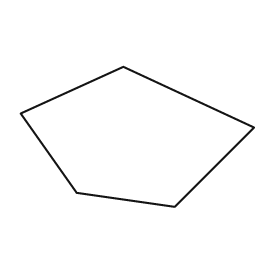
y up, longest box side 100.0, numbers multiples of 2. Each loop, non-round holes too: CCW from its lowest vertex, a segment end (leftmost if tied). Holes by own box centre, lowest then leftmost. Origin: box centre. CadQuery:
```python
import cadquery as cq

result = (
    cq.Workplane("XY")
    .moveTo(16.0, -30.0)
    .lineTo(50.0, 4.0)
    .lineTo(-6.0, 30.0)
    .lineTo(-50.0, 10.0)
    .lineTo(-26.0, -24.0)
    .close()
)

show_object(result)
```